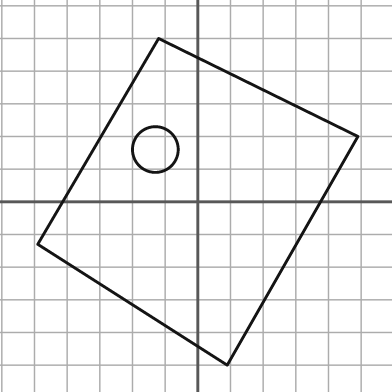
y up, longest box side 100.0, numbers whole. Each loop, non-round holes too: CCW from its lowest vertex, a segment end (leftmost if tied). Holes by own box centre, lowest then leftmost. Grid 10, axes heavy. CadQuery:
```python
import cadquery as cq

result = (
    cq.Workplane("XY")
    .moveTo(9.0, -50.0)
    .lineTo(49.0, 20.0)
    .lineTo(-12.0, 50.0)
    .lineTo(-49.0, -13.0)
    .close()
    .moveTo(-13.0, 16.0)
    .circle(7.0)
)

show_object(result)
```